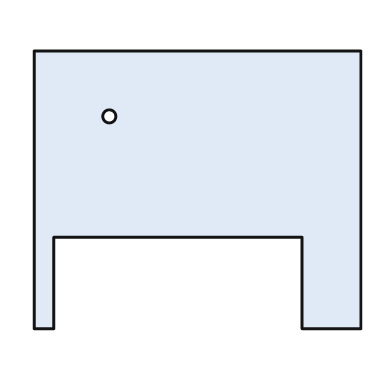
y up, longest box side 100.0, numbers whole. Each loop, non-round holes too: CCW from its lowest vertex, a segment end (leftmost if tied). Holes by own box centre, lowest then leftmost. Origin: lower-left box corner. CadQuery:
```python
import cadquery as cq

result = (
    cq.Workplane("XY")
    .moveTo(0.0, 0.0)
    .lineTo(6.0, 0.0)
    .lineTo(6.0, 28.0)
    .lineTo(82.0, 28.0)
    .lineTo(82.0, 0.0)
    .lineTo(100.0, 0.0)
    .lineTo(100.0, 85.0)
    .lineTo(0.0, 85.0)
    .close()
    .moveTo(23.0, 65.0)
    .circle(2.0)
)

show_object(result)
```